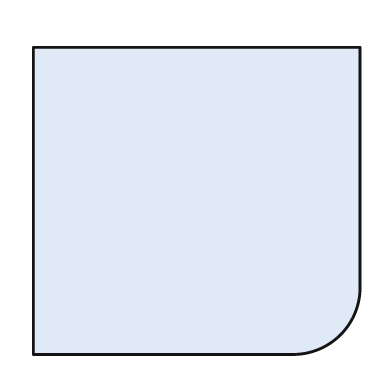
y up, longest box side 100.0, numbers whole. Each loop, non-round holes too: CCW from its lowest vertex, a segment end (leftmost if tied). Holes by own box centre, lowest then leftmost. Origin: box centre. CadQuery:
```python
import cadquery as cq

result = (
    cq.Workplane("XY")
    .moveTo(-50.0, -47.0)
    .lineTo(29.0, -47.0)
    .threePointArc((44.0, -41.0), (50.0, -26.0))
    .lineTo(50.0, 47.0)
    .lineTo(-50.0, 47.0)
    .close()
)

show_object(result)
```